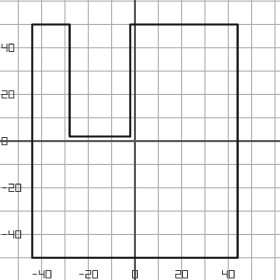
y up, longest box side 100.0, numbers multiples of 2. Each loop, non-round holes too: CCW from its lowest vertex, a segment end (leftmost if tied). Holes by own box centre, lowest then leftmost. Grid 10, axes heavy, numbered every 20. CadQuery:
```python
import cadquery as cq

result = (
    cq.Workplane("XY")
    .moveTo(-44.0, -50.0)
    .lineTo(44.0, -50.0)
    .lineTo(44.0, 50.0)
    .lineTo(-2.0, 50.0)
    .lineTo(-2.0, 2.0)
    .lineTo(-28.0, 2.0)
    .lineTo(-28.0, 50.0)
    .lineTo(-44.0, 50.0)
    .close()
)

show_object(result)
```